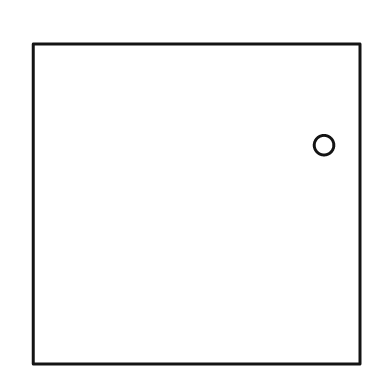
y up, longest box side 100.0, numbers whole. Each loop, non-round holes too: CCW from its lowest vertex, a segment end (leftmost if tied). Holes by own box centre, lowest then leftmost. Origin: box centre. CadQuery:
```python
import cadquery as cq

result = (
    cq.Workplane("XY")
    .moveTo(-50.0, -49.0)
    .lineTo(50.0, -49.0)
    .lineTo(50.0, 49.0)
    .lineTo(-50.0, 49.0)
    .close()
    .moveTo(39.0, 18.0)
    .circle(3.0)
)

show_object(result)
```